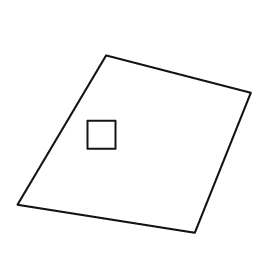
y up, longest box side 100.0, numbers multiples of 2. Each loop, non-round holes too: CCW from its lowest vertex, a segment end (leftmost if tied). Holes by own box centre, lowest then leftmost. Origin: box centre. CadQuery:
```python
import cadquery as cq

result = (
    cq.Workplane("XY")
    .moveTo(26.0, -38.0)
    .lineTo(50.0, 22.0)
    .lineTo(-12.0, 38.0)
    .lineTo(-50.0, -26.0)
    .close()
    .moveTo(-20.0, -2.0)
    .lineTo(-8.0, -2.0)
    .lineTo(-8.0, 10.0)
    .lineTo(-20.0, 10.0)
    .close()
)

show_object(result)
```